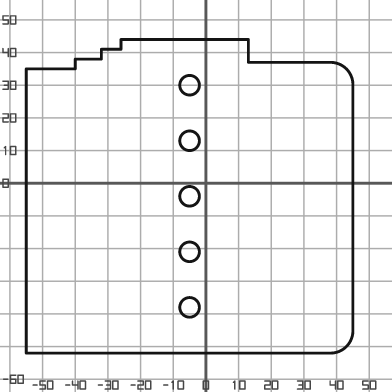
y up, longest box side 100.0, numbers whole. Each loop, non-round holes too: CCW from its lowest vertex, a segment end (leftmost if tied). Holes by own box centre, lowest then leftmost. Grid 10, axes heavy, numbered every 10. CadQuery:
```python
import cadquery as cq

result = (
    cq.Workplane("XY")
    .moveTo(-55.0, -52.0)
    .lineTo(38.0, -52.0)
    .threePointArc((43.0, -50.0), (45.0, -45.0))
    .lineTo(45.0, 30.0)
    .threePointArc((43.0, 35.0), (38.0, 37.0))
    .lineTo(13.0, 37.0)
    .lineTo(13.0, 44.0)
    .lineTo(-26.0, 44.0)
    .lineTo(-26.0, 41.0)
    .lineTo(-32.0, 41.0)
    .lineTo(-32.0, 38.0)
    .lineTo(-40.0, 38.0)
    .lineTo(-40.0, 35.0)
    .lineTo(-55.0, 35.0)
    .close()
    .moveTo(-5.0, -38.0)
    .circle(3.0)
    .moveTo(-5.0, -21.0)
    .circle(3.0)
    .moveTo(-5.0, -4.0)
    .circle(3.0)
    .moveTo(-5.0, 13.0)
    .circle(3.0)
    .moveTo(-5.0, 30.0)
    .circle(3.0)
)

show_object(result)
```